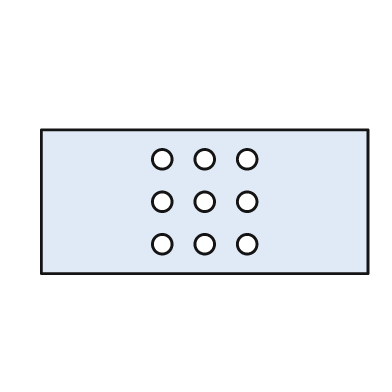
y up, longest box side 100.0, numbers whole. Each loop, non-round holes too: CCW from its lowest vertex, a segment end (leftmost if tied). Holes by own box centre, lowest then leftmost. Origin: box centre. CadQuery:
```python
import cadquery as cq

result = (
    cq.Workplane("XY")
    .moveTo(-50.0, -22.0)
    .lineTo(50.0, -22.0)
    .lineTo(50.0, 22.0)
    .lineTo(-50.0, 22.0)
    .close()
    .moveTo(-13.0, -13.0)
    .circle(3.0)
    .moveTo(0.0, -13.0)
    .circle(3.0)
    .moveTo(13.0, -13.0)
    .circle(3.0)
    .moveTo(-13.0, 0.0)
    .circle(3.0)
    .moveTo(0.0, 0.0)
    .circle(3.0)
    .moveTo(13.0, 0.0)
    .circle(3.0)
    .moveTo(-13.0, 13.0)
    .circle(3.0)
    .moveTo(0.0, 13.0)
    .circle(3.0)
    .moveTo(13.0, 13.0)
    .circle(3.0)
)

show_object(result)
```